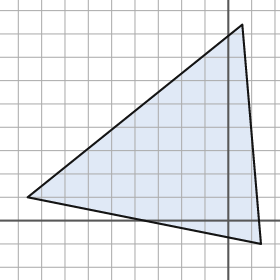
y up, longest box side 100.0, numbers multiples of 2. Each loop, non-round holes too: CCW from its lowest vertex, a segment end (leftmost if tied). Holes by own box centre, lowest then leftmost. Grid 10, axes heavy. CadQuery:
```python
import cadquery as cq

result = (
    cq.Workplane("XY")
    .moveTo(14.0, -10.0)
    .lineTo(6.0, 84.0)
    .lineTo(-86.0, 10.0)
    .close()
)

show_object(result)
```